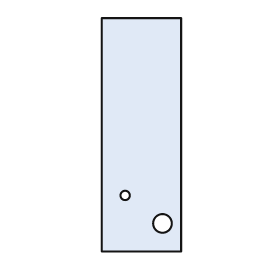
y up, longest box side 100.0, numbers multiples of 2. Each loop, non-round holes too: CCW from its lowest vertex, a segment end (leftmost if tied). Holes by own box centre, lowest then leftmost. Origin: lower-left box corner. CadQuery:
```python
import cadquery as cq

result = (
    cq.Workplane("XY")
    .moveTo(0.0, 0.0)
    .lineTo(34.0, 0.0)
    .lineTo(34.0, 100.0)
    .lineTo(0.0, 100.0)
    .close()
    .moveTo(26.0, 12.0)
    .circle(4.0)
    .moveTo(10.0, 24.0)
    .circle(2.0)
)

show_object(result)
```